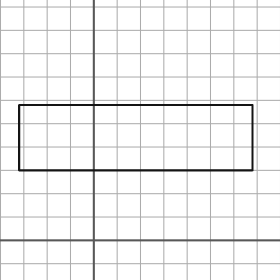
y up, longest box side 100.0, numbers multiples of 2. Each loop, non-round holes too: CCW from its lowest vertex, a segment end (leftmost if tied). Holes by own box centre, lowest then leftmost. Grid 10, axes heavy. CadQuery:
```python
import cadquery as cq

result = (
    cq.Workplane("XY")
    .moveTo(-32.0, 30.0)
    .lineTo(68.0, 30.0)
    .lineTo(68.0, 58.0)
    .lineTo(-32.0, 58.0)
    .close()
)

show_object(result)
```